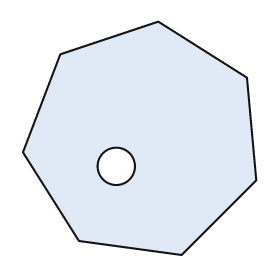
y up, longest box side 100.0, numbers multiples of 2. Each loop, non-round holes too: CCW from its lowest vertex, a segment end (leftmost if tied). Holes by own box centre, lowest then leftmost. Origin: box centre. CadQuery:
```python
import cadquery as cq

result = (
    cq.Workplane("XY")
    .moveTo(18.0, -50.0)
    .lineTo(50.0, -18.0)
    .lineTo(46.0, 26.0)
    .lineTo(8.0, 50.0)
    .lineTo(-34.0, 36.0)
    .lineTo(-50.0, -6.0)
    .lineTo(-26.0, -44.0)
    .close()
    .moveTo(-10.0, -12.0)
    .circle(8.0)
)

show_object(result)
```